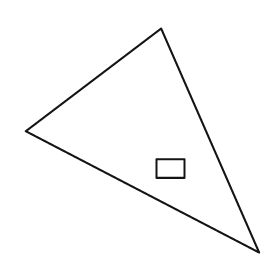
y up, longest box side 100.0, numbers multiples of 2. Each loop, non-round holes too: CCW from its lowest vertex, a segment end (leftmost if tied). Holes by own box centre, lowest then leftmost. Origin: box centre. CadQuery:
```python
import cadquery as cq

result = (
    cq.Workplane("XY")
    .moveTo(50.0, -48.0)
    .lineTo(8.0, 48.0)
    .lineTo(-50.0, 4.0)
    .close()
    .moveTo(6.0, -16.0)
    .lineTo(18.0, -16.0)
    .lineTo(18.0, -8.0)
    .lineTo(6.0, -8.0)
    .close()
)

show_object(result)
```